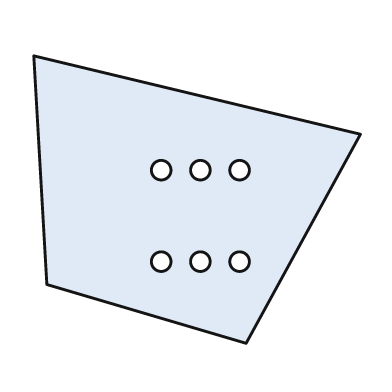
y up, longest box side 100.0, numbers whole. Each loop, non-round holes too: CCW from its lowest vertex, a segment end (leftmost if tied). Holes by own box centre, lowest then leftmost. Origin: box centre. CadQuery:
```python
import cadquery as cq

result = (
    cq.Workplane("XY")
    .moveTo(15.0, -44.0)
    .lineTo(50.0, 20.0)
    .lineTo(-50.0, 44.0)
    .lineTo(-46.0, -26.0)
    .close()
    .moveTo(-11.0, -19.0)
    .circle(3.0)
    .moveTo(1.0, -19.0)
    .circle(3.0)
    .moveTo(13.0, -19.0)
    .circle(3.0)
    .moveTo(-11.0, 9.0)
    .circle(3.0)
    .moveTo(1.0, 9.0)
    .circle(3.0)
    .moveTo(13.0, 9.0)
    .circle(3.0)
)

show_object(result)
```